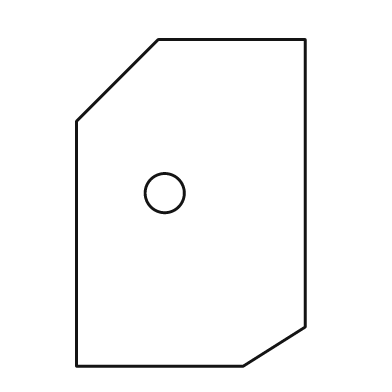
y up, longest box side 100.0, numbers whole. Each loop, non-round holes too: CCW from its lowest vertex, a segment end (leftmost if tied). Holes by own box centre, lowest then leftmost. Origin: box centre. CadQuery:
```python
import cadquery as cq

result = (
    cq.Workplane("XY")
    .moveTo(-35.0, -50.0)
    .lineTo(16.0, -50.0)
    .lineTo(35.0, -38.0)
    .lineTo(35.0, 50.0)
    .lineTo(-10.0, 50.0)
    .lineTo(-35.0, 25.0)
    .close()
    .moveTo(-8.0, 3.0)
    .circle(6.0)
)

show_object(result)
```